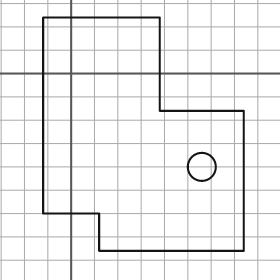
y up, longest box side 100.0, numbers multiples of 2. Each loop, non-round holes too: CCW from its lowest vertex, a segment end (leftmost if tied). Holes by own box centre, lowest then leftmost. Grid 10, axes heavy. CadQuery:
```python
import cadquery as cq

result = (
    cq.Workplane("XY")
    .moveTo(12.0, -76.0)
    .lineTo(74.0, -76.0)
    .lineTo(74.0, -16.0)
    .lineTo(38.0, -16.0)
    .lineTo(38.0, 24.0)
    .lineTo(-12.0, 24.0)
    .lineTo(-12.0, -60.0)
    .lineTo(12.0, -60.0)
    .close()
    .moveTo(56.0, -40.0)
    .circle(6.0)
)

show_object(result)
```